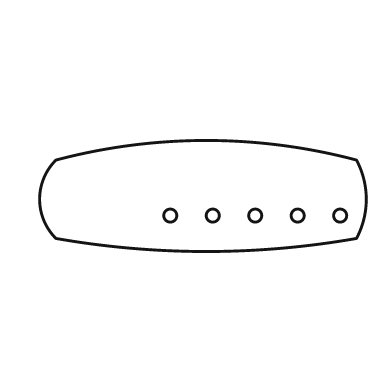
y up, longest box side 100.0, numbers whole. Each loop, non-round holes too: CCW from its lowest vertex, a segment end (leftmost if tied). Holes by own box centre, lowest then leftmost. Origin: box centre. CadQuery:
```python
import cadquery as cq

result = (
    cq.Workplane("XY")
    .moveTo(-45.0, -13.0)
    .threePointArc((1.0, -17.0), (47.0, -13.0))
    .threePointArc((50.0, -1.0), (47.0, 11.0))
    .threePointArc((1.0, 17.0), (-45.0, 11.0))
    .threePointArc((-50.0, -1.0), (-45.0, -13.0))
    .close()
    .moveTo(-10.0, -6.0)
    .circle(2.0)
    .moveTo(3.0, -6.0)
    .circle(2.0)
    .moveTo(16.0, -6.0)
    .circle(2.0)
    .moveTo(29.0, -6.0)
    .circle(2.0)
    .moveTo(42.0, -6.0)
    .circle(2.0)
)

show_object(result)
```